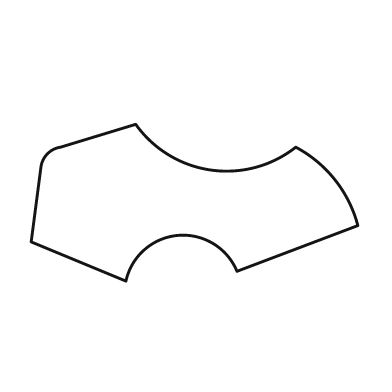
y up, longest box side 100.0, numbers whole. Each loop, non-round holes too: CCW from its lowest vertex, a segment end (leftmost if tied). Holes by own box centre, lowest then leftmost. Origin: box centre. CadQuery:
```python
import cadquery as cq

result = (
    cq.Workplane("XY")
    .moveTo(-21.0, -24.0)
    .threePointArc((-5.0, -10.0), (13.0, -21.0))
    .lineTo(50.0, -7.0)
    .threePointArc((43.0, 7.0), (31.0, 17.0))
    .threePointArc((5.0, 10.0), (-18.0, 24.0))
    .lineTo(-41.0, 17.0)
    .threePointArc((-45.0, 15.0), (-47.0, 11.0))
    .lineTo(-50.0, -12.0)
    .close()
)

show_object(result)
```